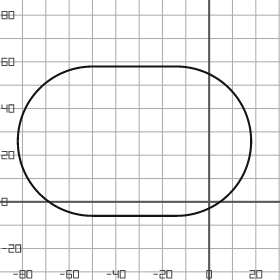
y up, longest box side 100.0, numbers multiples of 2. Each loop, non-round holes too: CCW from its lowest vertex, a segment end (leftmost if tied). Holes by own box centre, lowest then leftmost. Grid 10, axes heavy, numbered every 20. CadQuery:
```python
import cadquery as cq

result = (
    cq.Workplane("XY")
    .moveTo(-50.0, -6.0)
    .lineTo(-14.0, -6.0)
    .threePointArc((18.0, 26.0), (-14.0, 58.0))
    .lineTo(-50.0, 58.0)
    .threePointArc((-82.0, 26.0), (-50.0, -6.0))
    .close()
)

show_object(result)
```